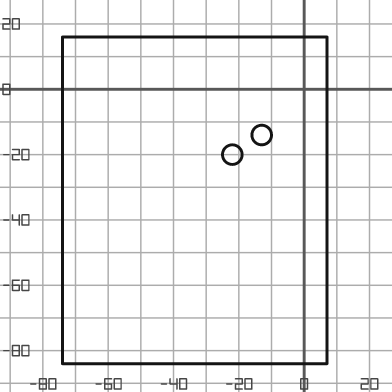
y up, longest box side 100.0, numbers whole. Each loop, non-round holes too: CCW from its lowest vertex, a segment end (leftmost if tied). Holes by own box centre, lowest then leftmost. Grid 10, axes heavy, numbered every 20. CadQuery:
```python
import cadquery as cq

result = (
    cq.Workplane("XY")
    .moveTo(-74.0, -84.0)
    .lineTo(7.0, -84.0)
    .lineTo(7.0, 16.0)
    .lineTo(-74.0, 16.0)
    .close()
    .moveTo(-22.0, -20.0)
    .circle(3.0)
    .moveTo(-13.0, -14.0)
    .circle(3.0)
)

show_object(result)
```